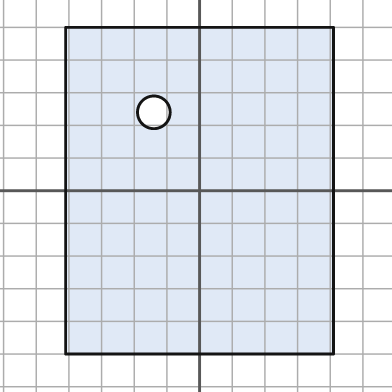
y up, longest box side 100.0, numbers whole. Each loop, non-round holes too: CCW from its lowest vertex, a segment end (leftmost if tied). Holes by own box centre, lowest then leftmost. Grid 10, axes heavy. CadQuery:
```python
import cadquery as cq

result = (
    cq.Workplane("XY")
    .moveTo(-41.0, -50.0)
    .lineTo(41.0, -50.0)
    .lineTo(41.0, 50.0)
    .lineTo(-41.0, 50.0)
    .close()
    .moveTo(-14.0, 24.0)
    .circle(5.0)
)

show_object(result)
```